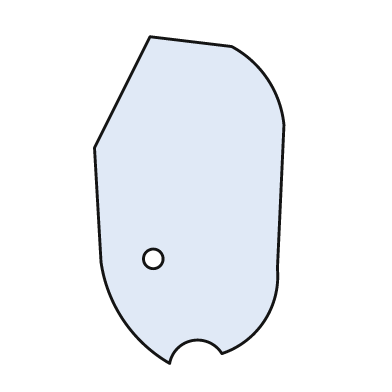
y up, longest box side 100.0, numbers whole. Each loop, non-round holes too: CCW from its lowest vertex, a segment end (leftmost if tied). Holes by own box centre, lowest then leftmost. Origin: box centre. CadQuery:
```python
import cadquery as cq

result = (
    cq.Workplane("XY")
    .moveTo(-6.0, -50.0)
    .threePointArc((1.0, -43.0), (10.0, -47.0))
    .threePointArc((23.0, -37.0), (27.0, -21.0))
    .lineTo(29.0, 23.0)
    .threePointArc((24.0, 37.0), (13.0, 47.0))
    .lineTo(-12.0, 50.0)
    .lineTo(-29.0, 16.0)
    .lineTo(-27.0, -19.0)
    .threePointArc((-20.0, -37.0), (-6.0, -50.0))
    .close()
    .moveTo(-11.0, -18.0)
    .circle(3.0)
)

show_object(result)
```